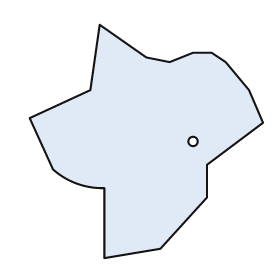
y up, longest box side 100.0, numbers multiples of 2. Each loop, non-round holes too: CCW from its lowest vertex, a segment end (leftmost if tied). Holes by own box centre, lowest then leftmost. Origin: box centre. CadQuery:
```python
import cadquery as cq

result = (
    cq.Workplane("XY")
    .moveTo(-18.0, -50.0)
    .lineTo(6.0, -46.0)
    .lineTo(26.0, -24.0)
    .lineTo(26.0, -10.0)
    .lineTo(50.0, 8.0)
    .lineTo(44.0, 22.0)
    .lineTo(34.0, 34.0)
    .lineTo(28.0, 38.0)
    .lineTo(20.0, 38.0)
    .lineTo(10.0, 34.0)
    .lineTo(0.0, 36.0)
    .lineTo(-20.0, 50.0)
    .lineTo(-24.0, 22.0)
    .lineTo(-50.0, 10.0)
    .lineTo(-40.0, -12.0)
    .threePointArc((-30.0, -18.0), (-18.0, -20.0))
    .close()
    .moveTo(20.0, 0.0)
    .circle(2.0)
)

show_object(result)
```